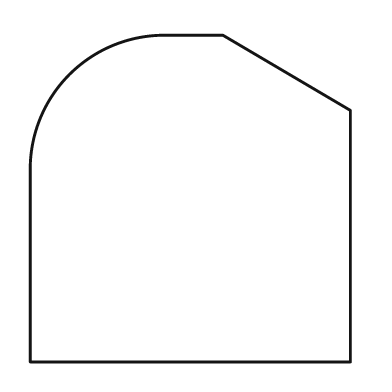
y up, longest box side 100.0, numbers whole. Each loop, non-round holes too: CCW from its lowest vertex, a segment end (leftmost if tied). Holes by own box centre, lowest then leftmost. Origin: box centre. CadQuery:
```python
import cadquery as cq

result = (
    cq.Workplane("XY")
    .moveTo(-49.0, -50.0)
    .lineTo(49.0, -50.0)
    .lineTo(49.0, 27.0)
    .lineTo(10.0, 50.0)
    .lineTo(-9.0, 50.0)
    .threePointArc((-37.0, 38.0), (-49.0, 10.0))
    .close()
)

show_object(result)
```